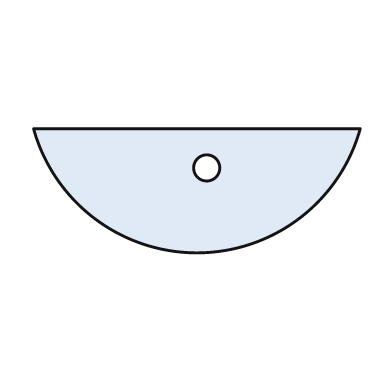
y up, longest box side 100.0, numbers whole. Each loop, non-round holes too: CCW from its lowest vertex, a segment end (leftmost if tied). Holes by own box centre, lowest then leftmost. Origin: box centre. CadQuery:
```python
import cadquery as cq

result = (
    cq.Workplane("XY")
    .moveTo(-50.0, 19.0)
    .threePointArc((0.0, -19.0), (50.0, 19.0))
    .close()
    .moveTo(3.0, 7.0)
    .circle(4.0)
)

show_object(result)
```